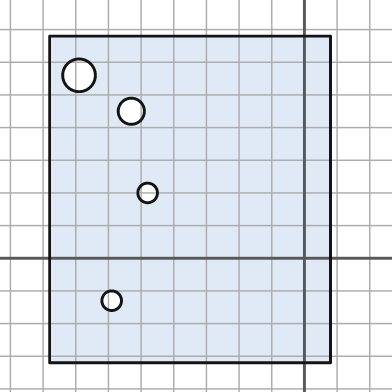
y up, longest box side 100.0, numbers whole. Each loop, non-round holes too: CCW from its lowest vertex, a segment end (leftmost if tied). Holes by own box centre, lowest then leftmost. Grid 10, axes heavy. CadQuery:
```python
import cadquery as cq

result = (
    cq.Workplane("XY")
    .moveTo(-78.0, -32.0)
    .lineTo(8.0, -32.0)
    .lineTo(8.0, 68.0)
    .lineTo(-78.0, 68.0)
    .close()
    .moveTo(-59.0, -13.0)
    .circle(3.0)
    .moveTo(-48.0, 20.0)
    .circle(3.0)
    .moveTo(-53.0, 45.0)
    .circle(4.0)
    .moveTo(-69.0, 56.0)
    .circle(5.0)
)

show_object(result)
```